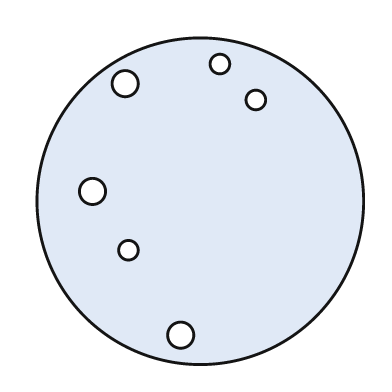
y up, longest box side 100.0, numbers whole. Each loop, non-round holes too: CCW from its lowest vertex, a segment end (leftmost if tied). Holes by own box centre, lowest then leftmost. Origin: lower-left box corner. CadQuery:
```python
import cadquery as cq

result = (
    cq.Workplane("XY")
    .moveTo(50.0, 50.0)
    .circle(50.0)
    .moveTo(44.0, 9.0)
    .circle(4.0)
    .moveTo(28.0, 35.0)
    .circle(3.0)
    .moveTo(17.0, 53.0)
    .circle(4.0)
    .moveTo(67.0, 81.0)
    .circle(3.0)
    .moveTo(27.0, 86.0)
    .circle(4.0)
    .moveTo(56.0, 92.0)
    .circle(3.0)
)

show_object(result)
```